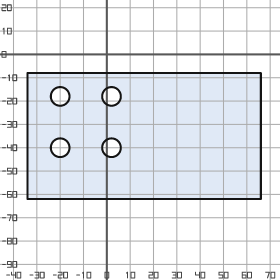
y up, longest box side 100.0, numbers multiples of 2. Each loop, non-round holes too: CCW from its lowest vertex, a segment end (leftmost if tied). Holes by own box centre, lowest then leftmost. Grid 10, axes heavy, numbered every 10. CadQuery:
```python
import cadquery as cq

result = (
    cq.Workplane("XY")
    .moveTo(-34.0, -62.0)
    .lineTo(66.0, -62.0)
    .lineTo(66.0, -8.0)
    .lineTo(-34.0, -8.0)
    .close()
    .moveTo(-20.0, -40.0)
    .circle(4.0)
    .moveTo(2.0, -40.0)
    .circle(4.0)
    .moveTo(-20.0, -18.0)
    .circle(4.0)
    .moveTo(2.0, -18.0)
    .circle(4.0)
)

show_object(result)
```